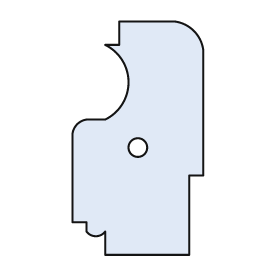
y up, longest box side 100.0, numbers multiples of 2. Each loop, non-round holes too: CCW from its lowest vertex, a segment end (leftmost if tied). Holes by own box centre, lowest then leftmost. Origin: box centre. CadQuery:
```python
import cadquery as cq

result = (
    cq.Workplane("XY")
    .moveTo(-14.0, -50.0)
    .lineTo(22.0, -50.0)
    .lineTo(22.0, -16.0)
    .lineTo(28.0, -16.0)
    .lineTo(28.0, 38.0)
    .threePointArc((24.0, 46.0), (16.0, 50.0))
    .lineTo(-8.0, 50.0)
    .lineTo(-8.0, 40.0)
    .lineTo(-14.0, 40.0)
    .threePointArc((-4.0, 24.0), (-14.0, 8.0))
    .lineTo(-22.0, 8.0)
    .threePointArc((-26.0, 6.0), (-28.0, 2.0))
    .lineTo(-28.0, -36.0)
    .lineTo(-22.0, -36.0)
    .lineTo(-22.0, -40.0)
    .threePointArc((-18.0, -42.0), (-14.0, -40.0))
    .close()
    .moveTo(0.0, -4.0)
    .circle(4.0)
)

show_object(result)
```